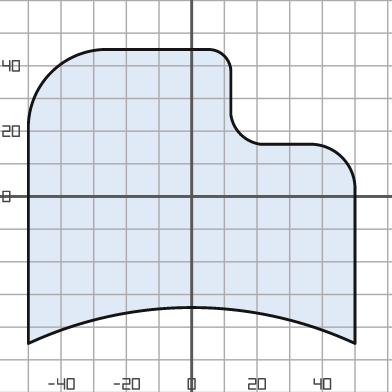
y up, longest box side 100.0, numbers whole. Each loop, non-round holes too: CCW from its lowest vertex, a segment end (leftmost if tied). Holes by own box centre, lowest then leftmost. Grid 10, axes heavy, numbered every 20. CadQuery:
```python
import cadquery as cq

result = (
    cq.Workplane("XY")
    .moveTo(-50.0, -45.0)
    .threePointArc((0.0, -34.0), (50.0, -45.0))
    .lineTo(50.0, 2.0)
    .threePointArc((46.0, 12.0), (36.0, 16.0))
    .lineTo(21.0, 16.0)
    .threePointArc((15.0, 19.0), (12.0, 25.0))
    .lineTo(12.0, 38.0)
    .threePointArc((10.0, 43.0), (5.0, 45.0))
    .lineTo(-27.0, 45.0)
    .threePointArc((-43.0, 38.0), (-50.0, 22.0))
    .close()
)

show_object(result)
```